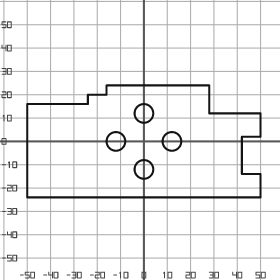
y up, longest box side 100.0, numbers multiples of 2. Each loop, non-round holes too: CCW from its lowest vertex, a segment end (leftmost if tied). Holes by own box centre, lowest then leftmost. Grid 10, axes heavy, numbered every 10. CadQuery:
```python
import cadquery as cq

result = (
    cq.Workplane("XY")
    .moveTo(-50.0, -24.0)
    .lineTo(50.0, -24.0)
    .lineTo(50.0, -14.0)
    .lineTo(42.0, -14.0)
    .lineTo(42.0, 2.0)
    .lineTo(50.0, 2.0)
    .lineTo(50.0, 12.0)
    .lineTo(28.0, 12.0)
    .lineTo(28.0, 24.0)
    .lineTo(-16.0, 24.0)
    .lineTo(-16.0, 20.0)
    .lineTo(-24.0, 20.0)
    .lineTo(-24.0, 16.0)
    .lineTo(-50.0, 16.0)
    .close()
    .moveTo(0.0, -12.0)
    .circle(4.0)
    .moveTo(-12.0, 0.0)
    .circle(4.0)
    .moveTo(12.0, 0.0)
    .circle(4.0)
    .moveTo(0.0, 12.0)
    .circle(4.0)
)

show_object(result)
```